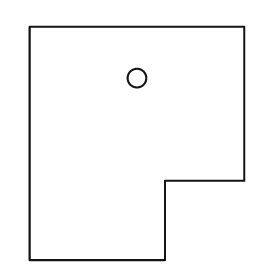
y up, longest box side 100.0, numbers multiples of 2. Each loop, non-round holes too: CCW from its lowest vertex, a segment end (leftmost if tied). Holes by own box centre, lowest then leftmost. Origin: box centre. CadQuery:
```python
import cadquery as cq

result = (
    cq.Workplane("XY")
    .moveTo(-46.0, -50.0)
    .lineTo(12.0, -50.0)
    .lineTo(12.0, -16.0)
    .lineTo(46.0, -16.0)
    .lineTo(46.0, 50.0)
    .lineTo(-46.0, 50.0)
    .close()
    .moveTo(0.0, 28.0)
    .circle(4.0)
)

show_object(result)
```